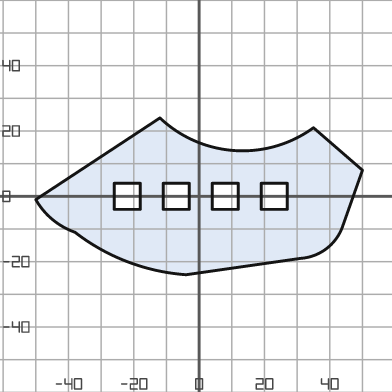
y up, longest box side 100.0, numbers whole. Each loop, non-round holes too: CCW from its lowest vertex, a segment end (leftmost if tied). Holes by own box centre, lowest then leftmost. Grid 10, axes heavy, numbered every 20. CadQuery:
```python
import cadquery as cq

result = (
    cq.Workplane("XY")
    .moveTo(-4.0, -24.0)
    .lineTo(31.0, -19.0)
    .threePointArc((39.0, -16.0), (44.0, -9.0))
    .lineTo(50.0, 8.0)
    .lineTo(35.0, 21.0)
    .threePointArc((11.0, 14.0), (-12.0, 24.0))
    .lineTo(-50.0, -1.0)
    .threePointArc((-45.0, -7.0), (-38.0, -11.0))
    .threePointArc((-22.0, -20.0), (-4.0, -24.0))
    .close()
    .moveTo(-26.0, -4.0)
    .lineTo(-18.0, -4.0)
    .lineTo(-18.0, 4.0)
    .lineTo(-26.0, 4.0)
    .close()
    .moveTo(-11.0, -4.0)
    .lineTo(-3.0, -4.0)
    .lineTo(-3.0, 4.0)
    .lineTo(-11.0, 4.0)
    .close()
    .moveTo(4.0, -4.0)
    .lineTo(12.0, -4.0)
    .lineTo(12.0, 4.0)
    .lineTo(4.0, 4.0)
    .close()
    .moveTo(19.0, -4.0)
    .lineTo(27.0, -4.0)
    .lineTo(27.0, 4.0)
    .lineTo(19.0, 4.0)
    .close()
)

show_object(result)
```